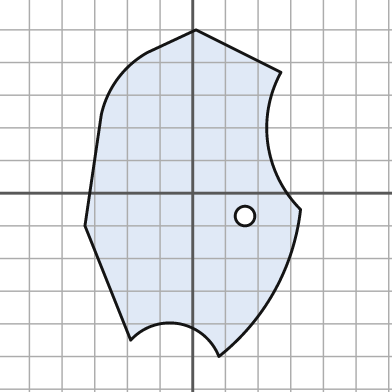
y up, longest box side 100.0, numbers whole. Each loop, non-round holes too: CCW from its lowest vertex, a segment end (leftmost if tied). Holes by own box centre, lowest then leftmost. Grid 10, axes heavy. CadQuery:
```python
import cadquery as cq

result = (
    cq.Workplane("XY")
    .moveTo(8.0, -50.0)
    .threePointArc((25.0, -30.0), (33.0, -5.0))
    .threePointArc((23.0, 15.0), (27.0, 37.0))
    .lineTo(1.0, 50.0)
    .lineTo(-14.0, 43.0)
    .threePointArc((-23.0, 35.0), (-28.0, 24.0))
    .lineTo(-33.0, -10.0)
    .lineTo(-19.0, -45.0)
    .threePointArc((-4.0, -40.0), (8.0, -50.0))
    .close()
    .moveTo(16.0, -7.0)
    .circle(3.0)
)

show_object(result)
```